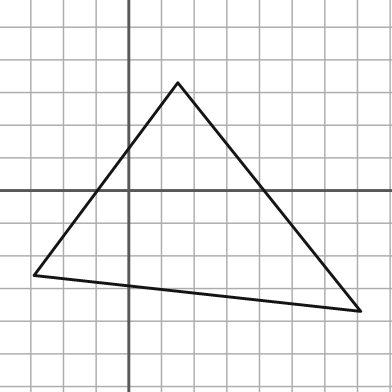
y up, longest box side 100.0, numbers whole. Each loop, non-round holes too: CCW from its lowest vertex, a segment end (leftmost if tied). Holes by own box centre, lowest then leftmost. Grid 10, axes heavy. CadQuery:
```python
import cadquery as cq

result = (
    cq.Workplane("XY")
    .moveTo(71.0, -37.0)
    .lineTo(15.0, 33.0)
    .lineTo(-29.0, -26.0)
    .close()
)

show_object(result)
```